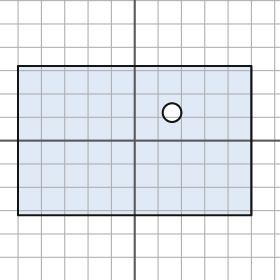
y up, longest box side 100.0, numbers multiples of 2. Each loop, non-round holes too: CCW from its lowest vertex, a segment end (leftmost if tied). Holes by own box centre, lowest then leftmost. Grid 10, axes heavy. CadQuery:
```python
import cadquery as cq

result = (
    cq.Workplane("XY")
    .moveTo(-50.0, -32.0)
    .lineTo(50.0, -32.0)
    .lineTo(50.0, 32.0)
    .lineTo(-50.0, 32.0)
    .close()
    .moveTo(16.0, 12.0)
    .circle(4.0)
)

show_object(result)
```